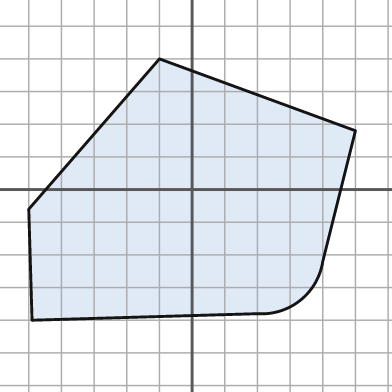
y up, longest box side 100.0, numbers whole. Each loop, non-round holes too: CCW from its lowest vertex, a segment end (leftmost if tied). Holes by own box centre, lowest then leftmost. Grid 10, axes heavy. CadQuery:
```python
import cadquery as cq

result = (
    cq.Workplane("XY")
    .moveTo(-49.0, -40.0)
    .lineTo(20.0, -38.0)
    .threePointArc((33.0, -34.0), (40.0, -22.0))
    .lineTo(50.0, 18.0)
    .lineTo(-10.0, 40.0)
    .lineTo(-50.0, -6.0)
    .close()
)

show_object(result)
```